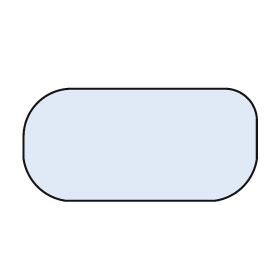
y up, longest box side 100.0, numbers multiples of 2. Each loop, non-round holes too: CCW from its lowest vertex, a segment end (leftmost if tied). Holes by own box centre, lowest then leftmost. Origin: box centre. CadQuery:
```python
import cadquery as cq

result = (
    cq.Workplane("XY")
    .moveTo(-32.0, -24.0)
    .lineTo(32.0, -24.0)
    .threePointArc((44.0, -18.0), (50.0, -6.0))
    .lineTo(50.0, 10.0)
    .threePointArc((46.0, 20.0), (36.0, 24.0))
    .lineTo(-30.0, 24.0)
    .threePointArc((-44.0, 18.0), (-50.0, 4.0))
    .lineTo(-50.0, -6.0)
    .threePointArc((-44.0, -18.0), (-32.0, -24.0))
    .close()
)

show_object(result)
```